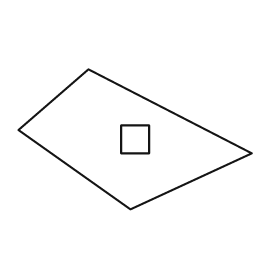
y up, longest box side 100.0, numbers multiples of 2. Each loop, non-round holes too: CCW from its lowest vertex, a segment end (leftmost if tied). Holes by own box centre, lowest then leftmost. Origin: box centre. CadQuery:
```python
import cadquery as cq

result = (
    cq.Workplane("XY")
    .moveTo(-2.0, -30.0)
    .lineTo(50.0, -6.0)
    .lineTo(-20.0, 30.0)
    .lineTo(-50.0, 4.0)
    .close()
    .moveTo(-6.0, -6.0)
    .lineTo(6.0, -6.0)
    .lineTo(6.0, 6.0)
    .lineTo(-6.0, 6.0)
    .close()
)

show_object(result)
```